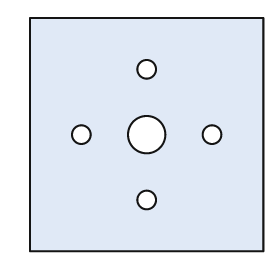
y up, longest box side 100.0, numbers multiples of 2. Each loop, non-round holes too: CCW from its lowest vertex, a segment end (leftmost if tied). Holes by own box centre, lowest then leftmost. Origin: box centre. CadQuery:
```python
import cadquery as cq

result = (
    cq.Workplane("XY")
    .moveTo(-50.0, -50.0)
    .lineTo(50.0, -50.0)
    .lineTo(50.0, 50.0)
    .lineTo(-50.0, 50.0)
    .close()
    .moveTo(0.0, -28.0)
    .circle(4.0)
    .moveTo(-28.0, 0.0)
    .circle(4.0)
    .moveTo(0.0, 0.0)
    .circle(8.0)
    .moveTo(28.0, 0.0)
    .circle(4.0)
    .moveTo(0.0, 28.0)
    .circle(4.0)
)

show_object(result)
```